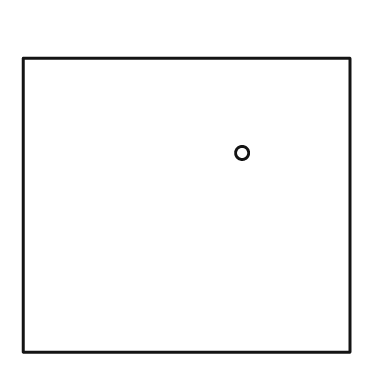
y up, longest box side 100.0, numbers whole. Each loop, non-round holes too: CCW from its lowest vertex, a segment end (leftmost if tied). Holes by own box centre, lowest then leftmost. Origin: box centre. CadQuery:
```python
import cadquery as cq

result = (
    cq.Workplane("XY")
    .moveTo(-50.0, -45.0)
    .lineTo(50.0, -45.0)
    .lineTo(50.0, 45.0)
    .lineTo(-50.0, 45.0)
    .close()
    .moveTo(17.0, 16.0)
    .circle(2.0)
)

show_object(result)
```